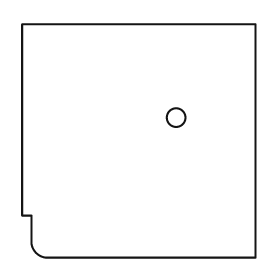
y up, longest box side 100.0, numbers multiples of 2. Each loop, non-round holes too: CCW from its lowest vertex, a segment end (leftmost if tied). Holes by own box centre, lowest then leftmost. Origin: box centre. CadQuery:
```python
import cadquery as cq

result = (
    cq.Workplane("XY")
    .moveTo(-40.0, -50.0)
    .lineTo(50.0, -50.0)
    .lineTo(50.0, 50.0)
    .lineTo(-50.0, 50.0)
    .lineTo(-50.0, -32.0)
    .lineTo(-46.0, -32.0)
    .lineTo(-46.0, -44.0)
    .threePointArc((-44.0, -48.0), (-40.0, -50.0))
    .close()
    .moveTo(16.0, 10.0)
    .circle(4.0)
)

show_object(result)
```